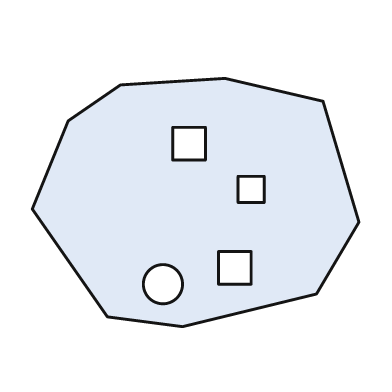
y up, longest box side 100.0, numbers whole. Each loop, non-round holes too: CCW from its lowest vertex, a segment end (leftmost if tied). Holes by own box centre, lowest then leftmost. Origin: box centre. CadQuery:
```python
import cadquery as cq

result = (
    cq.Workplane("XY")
    .moveTo(-4.0, -38.0)
    .lineTo(37.0, -28.0)
    .lineTo(50.0, -6.0)
    .lineTo(39.0, 31.0)
    .lineTo(9.0, 38.0)
    .lineTo(-23.0, 36.0)
    .lineTo(-39.0, 25.0)
    .lineTo(-50.0, -2.0)
    .lineTo(-27.0, -35.0)
    .close()
    .moveTo(-10.0, -25.0)
    .circle(6.0)
    .moveTo(7.0, -25.0)
    .lineTo(17.0, -25.0)
    .lineTo(17.0, -15.0)
    .lineTo(7.0, -15.0)
    .close()
    .moveTo(13.0, 0.0)
    .lineTo(21.0, 0.0)
    .lineTo(21.0, 8.0)
    .lineTo(13.0, 8.0)
    .close()
    .moveTo(-7.0, 13.0)
    .lineTo(3.0, 13.0)
    .lineTo(3.0, 23.0)
    .lineTo(-7.0, 23.0)
    .close()
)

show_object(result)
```